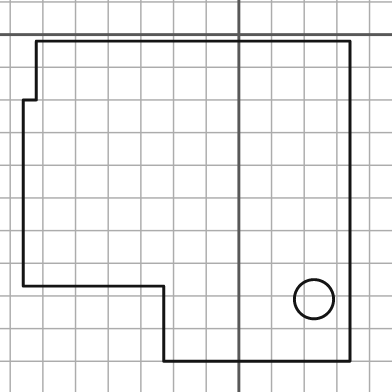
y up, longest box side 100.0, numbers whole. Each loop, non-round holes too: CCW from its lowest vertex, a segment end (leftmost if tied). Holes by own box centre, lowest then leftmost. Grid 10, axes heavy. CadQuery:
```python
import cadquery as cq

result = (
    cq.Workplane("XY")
    .moveTo(-23.0, -100.0)
    .lineTo(34.0, -100.0)
    .lineTo(34.0, -2.0)
    .lineTo(-62.0, -2.0)
    .lineTo(-62.0, -20.0)
    .lineTo(-66.0, -20.0)
    .lineTo(-66.0, -77.0)
    .lineTo(-23.0, -77.0)
    .close()
    .moveTo(23.0, -81.0)
    .circle(6.0)
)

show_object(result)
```